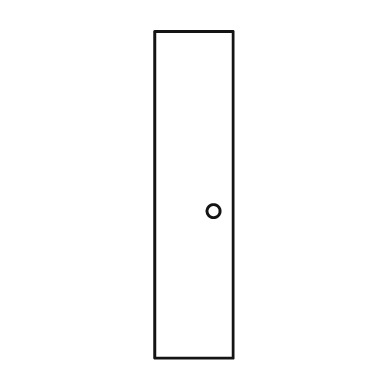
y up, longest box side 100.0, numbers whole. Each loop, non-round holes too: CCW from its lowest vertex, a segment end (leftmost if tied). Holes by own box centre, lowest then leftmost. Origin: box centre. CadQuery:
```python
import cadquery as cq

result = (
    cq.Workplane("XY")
    .moveTo(-12.0, -50.0)
    .lineTo(12.0, -50.0)
    .lineTo(12.0, 50.0)
    .lineTo(-12.0, 50.0)
    .close()
    .moveTo(6.0, -5.0)
    .circle(2.0)
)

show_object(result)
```